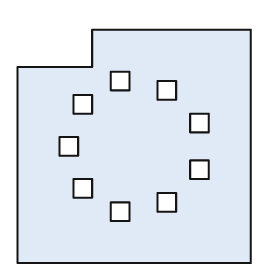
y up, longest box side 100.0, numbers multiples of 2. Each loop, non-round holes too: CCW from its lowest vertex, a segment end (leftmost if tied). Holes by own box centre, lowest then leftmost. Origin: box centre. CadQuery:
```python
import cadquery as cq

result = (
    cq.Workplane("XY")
    .moveTo(-50.0, -50.0)
    .lineTo(50.0, -50.0)
    .lineTo(50.0, 50.0)
    .lineTo(-18.0, 50.0)
    .lineTo(-18.0, 34.0)
    .lineTo(-50.0, 34.0)
    .close()
    .moveTo(-10.0, -32.0)
    .lineTo(-2.0, -32.0)
    .lineTo(-2.0, -24.0)
    .lineTo(-10.0, -24.0)
    .close()
    .moveTo(10.0, -28.0)
    .lineTo(18.0, -28.0)
    .lineTo(18.0, -20.0)
    .lineTo(10.0, -20.0)
    .close()
    .moveTo(-26.0, -22.0)
    .lineTo(-18.0, -22.0)
    .lineTo(-18.0, -14.0)
    .lineTo(-26.0, -14.0)
    .close()
    .moveTo(24.0, -14.0)
    .lineTo(32.0, -14.0)
    .lineTo(32.0, -6.0)
    .lineTo(24.0, -6.0)
    .close()
    .moveTo(-32.0, -4.0)
    .lineTo(-24.0, -4.0)
    .lineTo(-24.0, 4.0)
    .lineTo(-32.0, 4.0)
    .close()
    .moveTo(24.0, 6.0)
    .lineTo(32.0, 6.0)
    .lineTo(32.0, 14.0)
    .lineTo(24.0, 14.0)
    .close()
    .moveTo(-26.0, 14.0)
    .lineTo(-18.0, 14.0)
    .lineTo(-18.0, 22.0)
    .lineTo(-26.0, 22.0)
    .close()
    .moveTo(10.0, 20.0)
    .lineTo(18.0, 20.0)
    .lineTo(18.0, 28.0)
    .lineTo(10.0, 28.0)
    .close()
    .moveTo(-10.0, 24.0)
    .lineTo(-2.0, 24.0)
    .lineTo(-2.0, 32.0)
    .lineTo(-10.0, 32.0)
    .close()
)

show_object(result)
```